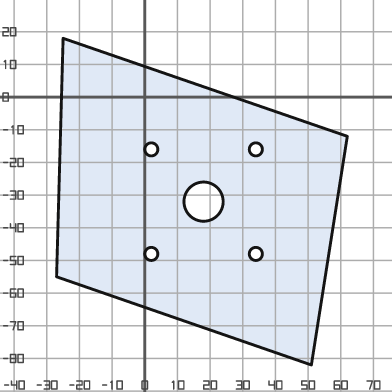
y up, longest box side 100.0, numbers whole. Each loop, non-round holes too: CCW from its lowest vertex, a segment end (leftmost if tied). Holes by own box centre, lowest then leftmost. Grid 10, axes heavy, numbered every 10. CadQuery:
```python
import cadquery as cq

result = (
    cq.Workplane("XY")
    .moveTo(51.0, -82.0)
    .lineTo(62.0, -12.0)
    .lineTo(-25.0, 18.0)
    .lineTo(-27.0, -55.0)
    .close()
    .moveTo(2.0, -48.0)
    .circle(2.0)
    .moveTo(34.0, -48.0)
    .circle(2.0)
    .moveTo(18.0, -32.0)
    .circle(6.0)
    .moveTo(2.0, -16.0)
    .circle(2.0)
    .moveTo(34.0, -16.0)
    .circle(2.0)
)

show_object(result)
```